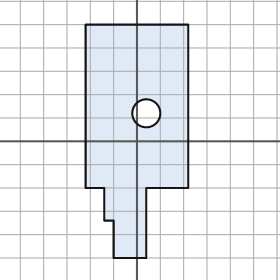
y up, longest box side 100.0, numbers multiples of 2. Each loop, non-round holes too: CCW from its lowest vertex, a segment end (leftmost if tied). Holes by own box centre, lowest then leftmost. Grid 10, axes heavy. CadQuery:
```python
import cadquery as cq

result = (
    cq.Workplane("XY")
    .moveTo(-10.0, -50.0)
    .lineTo(4.0, -50.0)
    .lineTo(4.0, -20.0)
    .lineTo(22.0, -20.0)
    .lineTo(22.0, 50.0)
    .lineTo(-22.0, 50.0)
    .lineTo(-22.0, -20.0)
    .lineTo(-14.0, -20.0)
    .lineTo(-14.0, -34.0)
    .lineTo(-10.0, -34.0)
    .close()
    .moveTo(4.0, 12.0)
    .circle(6.0)
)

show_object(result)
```